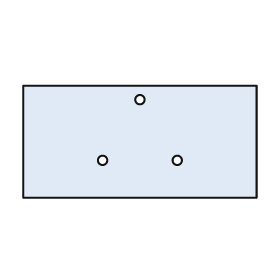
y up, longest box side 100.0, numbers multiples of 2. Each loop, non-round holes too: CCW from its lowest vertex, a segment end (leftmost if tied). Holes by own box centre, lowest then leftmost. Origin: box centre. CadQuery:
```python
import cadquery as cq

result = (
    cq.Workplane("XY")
    .moveTo(-50.0, -24.0)
    .lineTo(50.0, -24.0)
    .lineTo(50.0, 24.0)
    .lineTo(-50.0, 24.0)
    .close()
    .moveTo(-16.0, -8.0)
    .circle(2.0)
    .moveTo(16.0, -8.0)
    .circle(2.0)
    .moveTo(0.0, 18.0)
    .circle(2.0)
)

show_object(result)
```